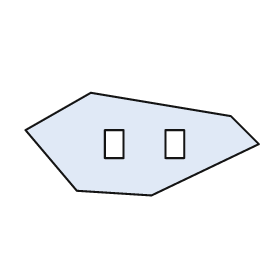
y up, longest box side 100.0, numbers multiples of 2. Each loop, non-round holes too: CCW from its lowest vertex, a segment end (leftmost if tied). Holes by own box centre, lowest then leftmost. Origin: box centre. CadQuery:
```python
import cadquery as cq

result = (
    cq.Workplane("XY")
    .moveTo(4.0, -22.0)
    .lineTo(50.0, 0.0)
    .lineTo(38.0, 12.0)
    .lineTo(-22.0, 22.0)
    .lineTo(-50.0, 6.0)
    .lineTo(-28.0, -20.0)
    .close()
    .moveTo(-16.0, -6.0)
    .lineTo(-8.0, -6.0)
    .lineTo(-8.0, 6.0)
    .lineTo(-16.0, 6.0)
    .close()
    .moveTo(10.0, -6.0)
    .lineTo(18.0, -6.0)
    .lineTo(18.0, 6.0)
    .lineTo(10.0, 6.0)
    .close()
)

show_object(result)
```